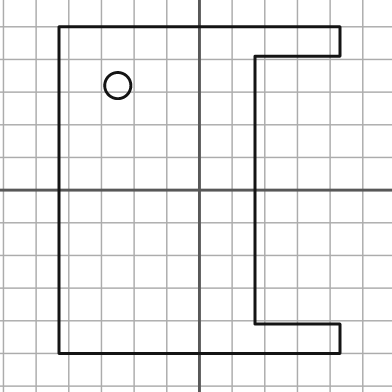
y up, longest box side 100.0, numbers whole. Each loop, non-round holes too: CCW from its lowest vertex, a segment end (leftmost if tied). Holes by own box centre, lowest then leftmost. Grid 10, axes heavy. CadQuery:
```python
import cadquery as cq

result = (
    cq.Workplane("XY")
    .moveTo(-43.0, -50.0)
    .lineTo(43.0, -50.0)
    .lineTo(43.0, -41.0)
    .lineTo(17.0, -41.0)
    .lineTo(17.0, 41.0)
    .lineTo(43.0, 41.0)
    .lineTo(43.0, 50.0)
    .lineTo(-43.0, 50.0)
    .close()
    .moveTo(-25.0, 32.0)
    .circle(4.0)
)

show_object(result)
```